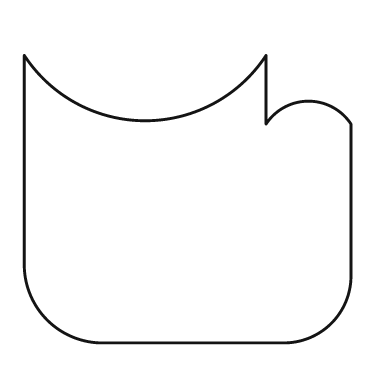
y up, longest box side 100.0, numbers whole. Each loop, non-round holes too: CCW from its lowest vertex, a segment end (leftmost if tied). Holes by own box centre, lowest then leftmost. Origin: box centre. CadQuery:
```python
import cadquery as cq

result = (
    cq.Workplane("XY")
    .moveTo(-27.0, -44.0)
    .lineTo(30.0, -44.0)
    .threePointArc((44.0, -38.0), (50.0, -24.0))
    .lineTo(50.0, 23.0)
    .threePointArc((37.0, 30.0), (24.0, 23.0))
    .lineTo(24.0, 44.0)
    .threePointArc((-13.0, 24.0), (-50.0, 44.0))
    .lineTo(-50.0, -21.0)
    .threePointArc((-43.0, -37.0), (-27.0, -44.0))
    .close()
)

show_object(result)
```